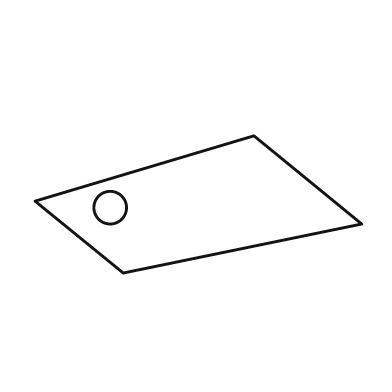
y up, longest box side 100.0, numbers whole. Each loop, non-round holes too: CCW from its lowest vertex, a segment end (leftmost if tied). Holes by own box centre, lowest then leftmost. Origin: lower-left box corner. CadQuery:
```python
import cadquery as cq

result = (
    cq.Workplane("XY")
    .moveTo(27.0, 0.0)
    .lineTo(100.0, 15.0)
    .lineTo(67.0, 42.0)
    .lineTo(0.0, 22.0)
    .close()
    .moveTo(23.0, 20.0)
    .circle(5.0)
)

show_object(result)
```